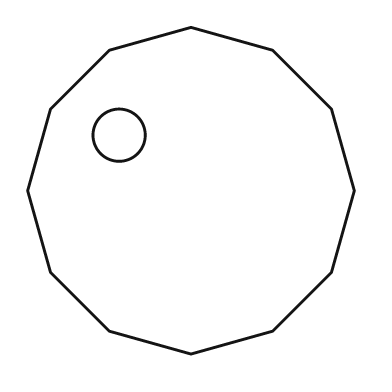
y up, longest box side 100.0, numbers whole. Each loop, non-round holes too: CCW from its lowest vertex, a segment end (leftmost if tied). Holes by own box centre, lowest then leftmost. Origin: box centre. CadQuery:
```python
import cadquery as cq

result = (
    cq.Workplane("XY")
    .moveTo(0.0, -50.0)
    .lineTo(25.0, -43.0)
    .lineTo(43.0, -25.0)
    .lineTo(50.0, 0.0)
    .lineTo(43.0, 25.0)
    .lineTo(25.0, 43.0)
    .lineTo(0.0, 50.0)
    .lineTo(-25.0, 43.0)
    .lineTo(-43.0, 25.0)
    .lineTo(-50.0, 0.0)
    .lineTo(-43.0, -25.0)
    .lineTo(-25.0, -43.0)
    .close()
    .moveTo(-22.0, 17.0)
    .circle(8.0)
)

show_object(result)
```